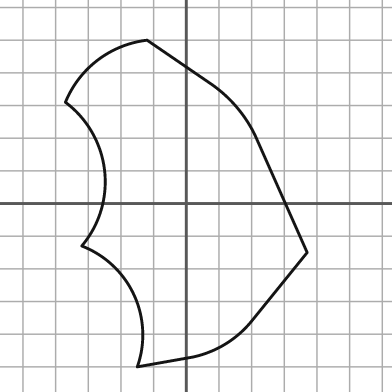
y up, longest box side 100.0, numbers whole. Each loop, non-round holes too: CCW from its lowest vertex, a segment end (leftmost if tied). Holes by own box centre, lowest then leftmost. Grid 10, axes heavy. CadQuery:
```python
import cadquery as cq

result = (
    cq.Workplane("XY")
    .moveTo(-15.0, -50.0)
    .lineTo(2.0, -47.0)
    .threePointArc((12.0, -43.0), (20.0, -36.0))
    .lineTo(37.0, -15.0)
    .lineTo(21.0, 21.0)
    .threePointArc((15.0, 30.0), (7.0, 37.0))
    .lineTo(-12.0, 50.0)
    .threePointArc((-27.0, 44.0), (-37.0, 31.0))
    .threePointArc((-25.0, 10.0), (-32.0, -13.0))
    .threePointArc((-16.0, -28.0), (-15.0, -50.0))
    .close()
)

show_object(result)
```